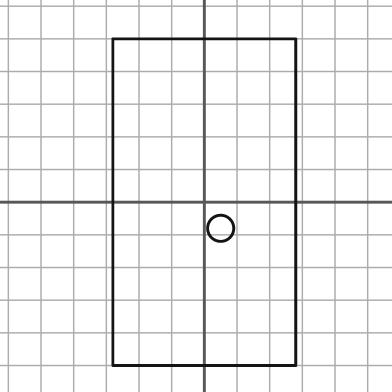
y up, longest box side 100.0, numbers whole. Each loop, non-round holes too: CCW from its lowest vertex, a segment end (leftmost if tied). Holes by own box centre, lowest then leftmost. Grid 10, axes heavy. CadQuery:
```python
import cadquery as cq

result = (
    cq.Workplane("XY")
    .moveTo(-28.0, -50.0)
    .lineTo(28.0, -50.0)
    .lineTo(28.0, 50.0)
    .lineTo(-28.0, 50.0)
    .close()
    .moveTo(5.0, -8.0)
    .circle(4.0)
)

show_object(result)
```